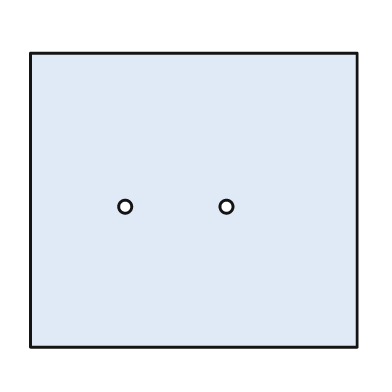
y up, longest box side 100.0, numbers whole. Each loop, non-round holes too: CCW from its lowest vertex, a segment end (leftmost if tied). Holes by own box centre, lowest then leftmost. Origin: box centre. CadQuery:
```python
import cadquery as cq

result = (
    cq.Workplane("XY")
    .moveTo(-50.0, -45.0)
    .lineTo(50.0, -45.0)
    .lineTo(50.0, 45.0)
    .lineTo(-50.0, 45.0)
    .close()
    .moveTo(-21.0, -2.0)
    .circle(2.0)
    .moveTo(10.0, -2.0)
    .circle(2.0)
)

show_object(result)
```